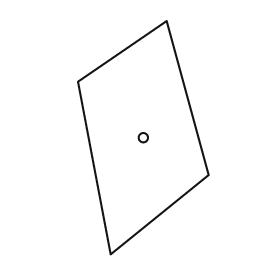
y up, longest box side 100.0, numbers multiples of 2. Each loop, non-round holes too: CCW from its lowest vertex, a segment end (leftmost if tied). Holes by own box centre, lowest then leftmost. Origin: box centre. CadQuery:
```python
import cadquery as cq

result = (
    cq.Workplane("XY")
    .moveTo(-14.0, -50.0)
    .lineTo(28.0, -16.0)
    .lineTo(10.0, 50.0)
    .lineTo(-28.0, 24.0)
    .close()
    .moveTo(0.0, 0.0)
    .circle(2.0)
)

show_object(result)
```